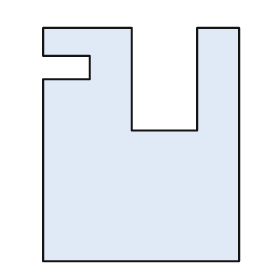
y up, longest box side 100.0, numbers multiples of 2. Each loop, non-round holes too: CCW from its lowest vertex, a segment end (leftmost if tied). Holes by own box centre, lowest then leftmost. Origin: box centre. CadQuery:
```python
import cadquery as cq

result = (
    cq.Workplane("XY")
    .moveTo(-42.0, -50.0)
    .lineTo(42.0, -50.0)
    .lineTo(42.0, 50.0)
    .lineTo(24.0, 50.0)
    .lineTo(24.0, 6.0)
    .lineTo(-4.0, 6.0)
    .lineTo(-4.0, 50.0)
    .lineTo(-42.0, 50.0)
    .lineTo(-42.0, 38.0)
    .lineTo(-22.0, 38.0)
    .lineTo(-22.0, 28.0)
    .lineTo(-42.0, 28.0)
    .close()
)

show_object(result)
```